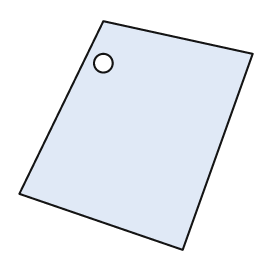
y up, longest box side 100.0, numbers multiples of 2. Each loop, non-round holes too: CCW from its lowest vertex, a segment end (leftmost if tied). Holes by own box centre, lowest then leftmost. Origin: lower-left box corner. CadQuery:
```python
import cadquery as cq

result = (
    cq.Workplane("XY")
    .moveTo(70.0, 0.0)
    .lineTo(100.0, 84.0)
    .lineTo(36.0, 98.0)
    .lineTo(0.0, 24.0)
    .close()
    .moveTo(36.0, 80.0)
    .circle(4.0)
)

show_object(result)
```